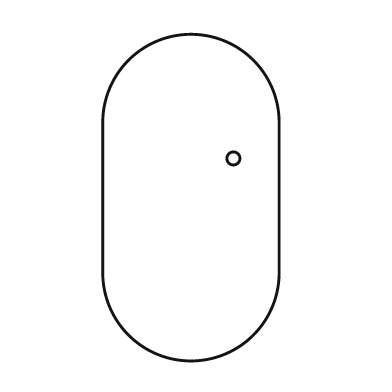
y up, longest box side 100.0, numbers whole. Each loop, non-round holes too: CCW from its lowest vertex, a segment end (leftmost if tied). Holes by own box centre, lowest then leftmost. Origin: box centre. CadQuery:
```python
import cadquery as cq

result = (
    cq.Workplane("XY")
    .moveTo(-27.0, -23.0)
    .threePointArc((0.0, -50.0), (27.0, -23.0))
    .lineTo(27.0, 23.0)
    .threePointArc((0.0, 50.0), (-27.0, 23.0))
    .close()
    .moveTo(13.0, 12.0)
    .circle(2.0)
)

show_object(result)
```